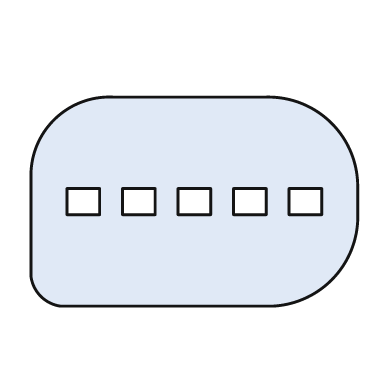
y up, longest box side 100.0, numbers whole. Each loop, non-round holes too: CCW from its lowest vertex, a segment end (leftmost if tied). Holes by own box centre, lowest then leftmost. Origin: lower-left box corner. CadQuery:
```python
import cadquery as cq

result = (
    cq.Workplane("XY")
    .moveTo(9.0, 0.0)
    .lineTo(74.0, 0.0)
    .threePointArc((92.0, 8.0), (100.0, 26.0))
    .lineTo(100.0, 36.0)
    .threePointArc((92.0, 56.0), (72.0, 64.0))
    .lineTo(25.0, 64.0)
    .threePointArc((7.0, 57.0), (0.0, 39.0))
    .lineTo(0.0, 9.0)
    .threePointArc((3.0, 3.0), (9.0, 0.0))
    .close()
    .moveTo(11.0, 28.0)
    .lineTo(21.0, 28.0)
    .lineTo(21.0, 36.0)
    .lineTo(11.0, 36.0)
    .close()
    .moveTo(28.0, 28.0)
    .lineTo(38.0, 28.0)
    .lineTo(38.0, 36.0)
    .lineTo(28.0, 36.0)
    .close()
    .moveTo(45.0, 28.0)
    .lineTo(55.0, 28.0)
    .lineTo(55.0, 36.0)
    .lineTo(45.0, 36.0)
    .close()
    .moveTo(62.0, 28.0)
    .lineTo(72.0, 28.0)
    .lineTo(72.0, 36.0)
    .lineTo(62.0, 36.0)
    .close()
    .moveTo(79.0, 28.0)
    .lineTo(89.0, 28.0)
    .lineTo(89.0, 36.0)
    .lineTo(79.0, 36.0)
    .close()
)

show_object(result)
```